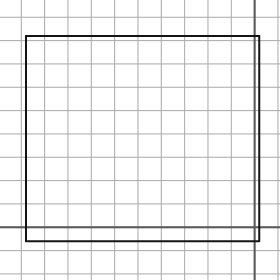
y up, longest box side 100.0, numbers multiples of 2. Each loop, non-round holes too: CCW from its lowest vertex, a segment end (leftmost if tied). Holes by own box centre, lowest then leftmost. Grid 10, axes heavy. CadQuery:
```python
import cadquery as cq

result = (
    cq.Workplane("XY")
    .moveTo(-98.0, -6.0)
    .lineTo(2.0, -6.0)
    .lineTo(2.0, 82.0)
    .lineTo(-98.0, 82.0)
    .close()
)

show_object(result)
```